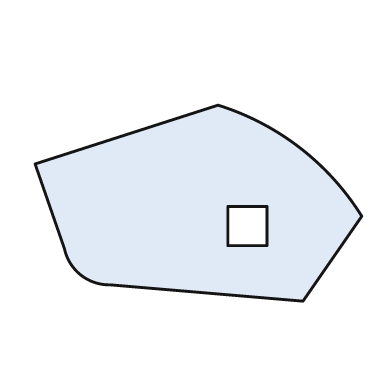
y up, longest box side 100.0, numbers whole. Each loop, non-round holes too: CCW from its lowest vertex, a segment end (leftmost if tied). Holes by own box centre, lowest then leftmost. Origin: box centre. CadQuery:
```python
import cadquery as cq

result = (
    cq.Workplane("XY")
    .moveTo(32.0, -30.0)
    .lineTo(50.0, -4.0)
    .threePointArc((31.0, 17.0), (6.0, 30.0))
    .lineTo(-50.0, 12.0)
    .lineTo(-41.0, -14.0)
    .threePointArc((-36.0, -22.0), (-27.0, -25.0))
    .close()
    .moveTo(9.0, -13.0)
    .lineTo(21.0, -13.0)
    .lineTo(21.0, -1.0)
    .lineTo(9.0, -1.0)
    .close()
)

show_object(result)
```